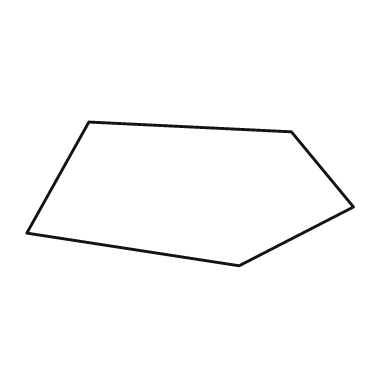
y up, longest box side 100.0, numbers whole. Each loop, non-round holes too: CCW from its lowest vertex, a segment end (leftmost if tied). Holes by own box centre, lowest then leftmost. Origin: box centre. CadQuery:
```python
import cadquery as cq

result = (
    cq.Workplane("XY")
    .moveTo(15.0, -22.0)
    .lineTo(50.0, -4.0)
    .lineTo(31.0, 19.0)
    .lineTo(-31.0, 22.0)
    .lineTo(-50.0, -12.0)
    .close()
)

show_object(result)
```